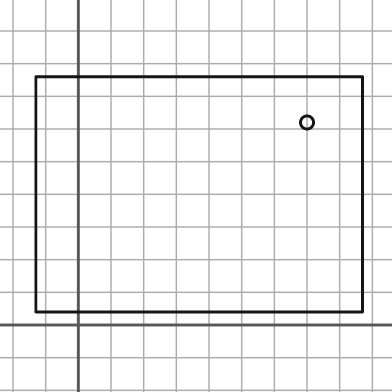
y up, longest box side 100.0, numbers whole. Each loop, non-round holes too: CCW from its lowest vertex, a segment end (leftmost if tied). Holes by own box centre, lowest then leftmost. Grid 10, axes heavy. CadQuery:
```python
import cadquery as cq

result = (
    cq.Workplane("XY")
    .moveTo(-13.0, 4.0)
    .lineTo(87.0, 4.0)
    .lineTo(87.0, 76.0)
    .lineTo(-13.0, 76.0)
    .close()
    .moveTo(70.0, 62.0)
    .circle(2.0)
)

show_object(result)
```